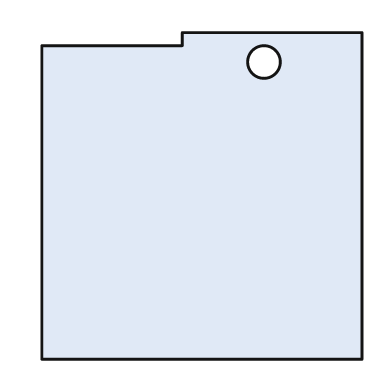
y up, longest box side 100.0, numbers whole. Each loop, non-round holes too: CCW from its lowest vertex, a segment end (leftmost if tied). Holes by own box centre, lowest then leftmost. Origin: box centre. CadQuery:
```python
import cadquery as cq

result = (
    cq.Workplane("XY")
    .moveTo(-49.0, -50.0)
    .lineTo(49.0, -50.0)
    .lineTo(49.0, 50.0)
    .lineTo(-6.0, 50.0)
    .lineTo(-6.0, 46.0)
    .lineTo(-49.0, 46.0)
    .close()
    .moveTo(19.0, 41.0)
    .circle(5.0)
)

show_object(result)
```